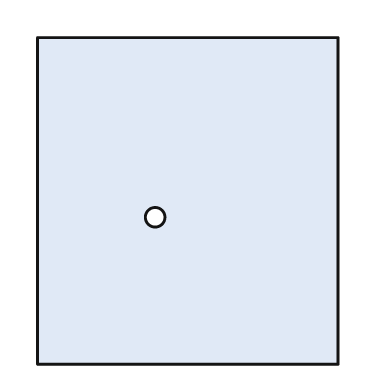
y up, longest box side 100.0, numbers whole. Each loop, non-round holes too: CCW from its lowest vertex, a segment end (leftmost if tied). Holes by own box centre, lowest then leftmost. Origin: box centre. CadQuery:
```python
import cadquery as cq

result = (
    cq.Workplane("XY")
    .moveTo(-46.0, -50.0)
    .lineTo(46.0, -50.0)
    .lineTo(46.0, 50.0)
    .lineTo(-46.0, 50.0)
    .close()
    .moveTo(-10.0, -5.0)
    .circle(3.0)
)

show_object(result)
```